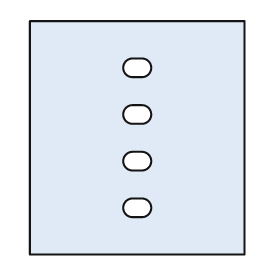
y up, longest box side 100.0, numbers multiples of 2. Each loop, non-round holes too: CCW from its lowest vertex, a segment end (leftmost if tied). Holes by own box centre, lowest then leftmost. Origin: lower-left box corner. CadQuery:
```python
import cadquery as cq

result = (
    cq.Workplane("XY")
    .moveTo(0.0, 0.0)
    .lineTo(92.0, 0.0)
    .lineTo(92.0, 100.0)
    .lineTo(0.0, 100.0)
    .close()
    .moveTo(44.0, 16.0)
    .lineTo(48.0, 16.0)
    .threePointArc((52.0, 20.0), (48.0, 24.0))
    .lineTo(44.0, 24.0)
    .threePointArc((40.0, 20.0), (44.0, 16.0))
    .close()
    .moveTo(44.0, 36.0)
    .lineTo(48.0, 36.0)
    .threePointArc((52.0, 40.0), (48.0, 44.0))
    .lineTo(44.0, 44.0)
    .threePointArc((40.0, 40.0), (44.0, 36.0))
    .close()
    .moveTo(44.0, 56.0)
    .lineTo(48.0, 56.0)
    .threePointArc((52.0, 60.0), (48.0, 64.0))
    .lineTo(44.0, 64.0)
    .threePointArc((40.0, 60.0), (44.0, 56.0))
    .close()
    .moveTo(44.0, 76.0)
    .lineTo(48.0, 76.0)
    .threePointArc((52.0, 80.0), (48.0, 84.0))
    .lineTo(44.0, 84.0)
    .threePointArc((40.0, 80.0), (44.0, 76.0))
    .close()
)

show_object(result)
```